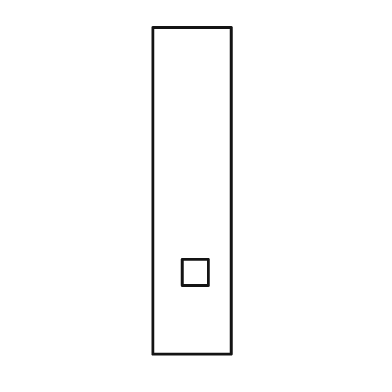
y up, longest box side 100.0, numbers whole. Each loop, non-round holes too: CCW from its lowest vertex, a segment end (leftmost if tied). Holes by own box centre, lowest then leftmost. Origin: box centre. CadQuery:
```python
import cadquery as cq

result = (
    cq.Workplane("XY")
    .moveTo(-12.0, -50.0)
    .lineTo(12.0, -50.0)
    .lineTo(12.0, 50.0)
    .lineTo(-12.0, 50.0)
    .close()
    .moveTo(-3.0, -29.0)
    .lineTo(5.0, -29.0)
    .lineTo(5.0, -21.0)
    .lineTo(-3.0, -21.0)
    .close()
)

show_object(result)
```